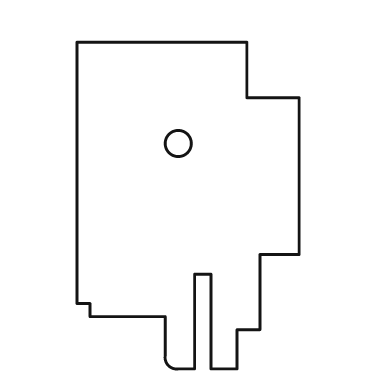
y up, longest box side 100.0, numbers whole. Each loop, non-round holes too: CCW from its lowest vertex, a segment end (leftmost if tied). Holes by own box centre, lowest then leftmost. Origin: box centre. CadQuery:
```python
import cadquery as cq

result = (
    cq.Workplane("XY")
    .moveTo(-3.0, -50.0)
    .lineTo(2.0, -50.0)
    .lineTo(2.0, -21.0)
    .lineTo(7.0, -21.0)
    .lineTo(7.0, -50.0)
    .lineTo(15.0, -50.0)
    .lineTo(15.0, -38.0)
    .lineTo(22.0, -38.0)
    .lineTo(22.0, -15.0)
    .lineTo(34.0, -15.0)
    .lineTo(34.0, 33.0)
    .lineTo(18.0, 33.0)
    .lineTo(18.0, 50.0)
    .lineTo(-34.0, 50.0)
    .lineTo(-34.0, -30.0)
    .lineTo(-30.0, -30.0)
    .lineTo(-30.0, -34.0)
    .lineTo(-7.0, -34.0)
    .lineTo(-7.0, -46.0)
    .threePointArc((-6.0, -49.0), (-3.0, -50.0))
    .close()
    .moveTo(-3.0, 19.0)
    .circle(4.0)
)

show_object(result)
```